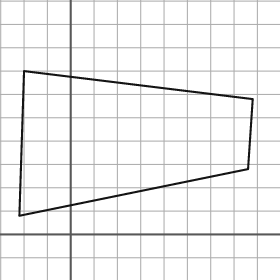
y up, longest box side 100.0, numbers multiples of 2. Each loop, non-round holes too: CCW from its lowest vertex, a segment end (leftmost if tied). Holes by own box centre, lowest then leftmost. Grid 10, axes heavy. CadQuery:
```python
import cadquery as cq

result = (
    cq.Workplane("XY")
    .moveTo(-22.0, 8.0)
    .lineTo(76.0, 28.0)
    .lineTo(78.0, 58.0)
    .lineTo(-20.0, 70.0)
    .close()
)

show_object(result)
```